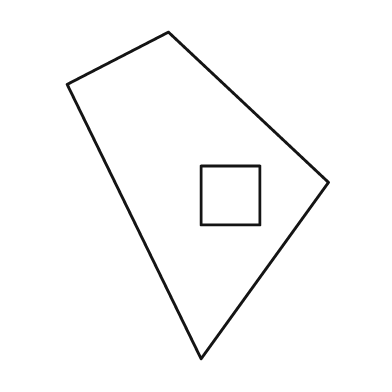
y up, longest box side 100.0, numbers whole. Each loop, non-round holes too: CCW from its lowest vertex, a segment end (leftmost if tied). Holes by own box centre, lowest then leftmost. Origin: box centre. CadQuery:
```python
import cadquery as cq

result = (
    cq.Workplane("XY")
    .moveTo(1.0, -50.0)
    .lineTo(40.0, 4.0)
    .lineTo(-9.0, 50.0)
    .lineTo(-40.0, 34.0)
    .close()
    .moveTo(1.0, -9.0)
    .lineTo(19.0, -9.0)
    .lineTo(19.0, 9.0)
    .lineTo(1.0, 9.0)
    .close()
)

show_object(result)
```